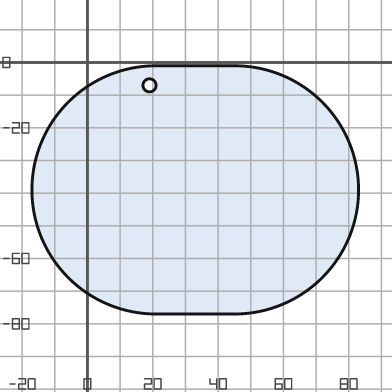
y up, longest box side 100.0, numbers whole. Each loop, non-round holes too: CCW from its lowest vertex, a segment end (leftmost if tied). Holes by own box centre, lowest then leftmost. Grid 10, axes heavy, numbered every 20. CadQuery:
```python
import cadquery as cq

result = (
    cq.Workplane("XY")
    .moveTo(21.0, -77.0)
    .lineTo(45.0, -77.0)
    .threePointArc((83.0, -39.0), (45.0, -1.0))
    .lineTo(21.0, -1.0)
    .threePointArc((-17.0, -39.0), (21.0, -77.0))
    .close()
    .moveTo(19.0, -7.0)
    .circle(2.0)
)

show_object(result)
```